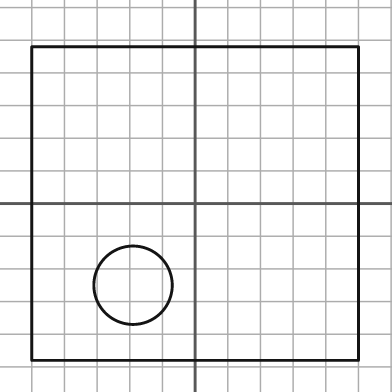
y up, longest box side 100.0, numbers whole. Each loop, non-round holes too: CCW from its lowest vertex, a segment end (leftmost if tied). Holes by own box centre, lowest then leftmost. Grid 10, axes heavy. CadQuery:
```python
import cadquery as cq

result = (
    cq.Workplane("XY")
    .moveTo(-50.0, -48.0)
    .lineTo(50.0, -48.0)
    .lineTo(50.0, 48.0)
    .lineTo(-50.0, 48.0)
    .close()
    .moveTo(-19.0, -25.0)
    .circle(12.0)
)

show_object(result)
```